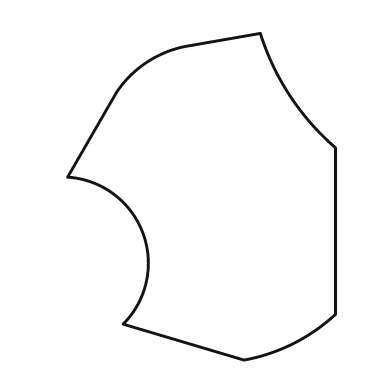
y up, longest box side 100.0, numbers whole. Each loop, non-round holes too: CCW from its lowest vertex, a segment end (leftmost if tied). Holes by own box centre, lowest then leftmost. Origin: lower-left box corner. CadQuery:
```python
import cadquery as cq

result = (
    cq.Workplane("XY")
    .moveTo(54.0, 0.0)
    .threePointArc((69.0, 5.0), (82.0, 14.0))
    .lineTo(82.0, 65.0)
    .threePointArc((68.0, 81.0), (59.0, 100.0))
    .lineTo(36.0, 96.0)
    .threePointArc((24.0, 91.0), (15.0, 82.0))
    .lineTo(0.0, 56.0)
    .threePointArc((23.0, 39.0), (17.0, 11.0))
    .close()
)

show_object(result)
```